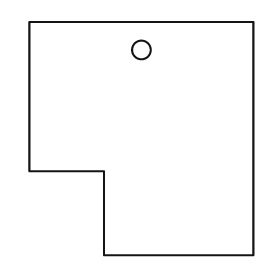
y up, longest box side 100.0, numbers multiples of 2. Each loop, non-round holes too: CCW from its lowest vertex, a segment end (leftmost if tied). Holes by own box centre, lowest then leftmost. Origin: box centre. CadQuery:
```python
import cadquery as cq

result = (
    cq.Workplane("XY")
    .moveTo(-16.0, -50.0)
    .lineTo(48.0, -50.0)
    .lineTo(48.0, 50.0)
    .lineTo(-48.0, 50.0)
    .lineTo(-48.0, -14.0)
    .lineTo(-16.0, -14.0)
    .close()
    .moveTo(0.0, 38.0)
    .circle(4.0)
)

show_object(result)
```